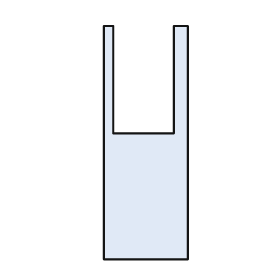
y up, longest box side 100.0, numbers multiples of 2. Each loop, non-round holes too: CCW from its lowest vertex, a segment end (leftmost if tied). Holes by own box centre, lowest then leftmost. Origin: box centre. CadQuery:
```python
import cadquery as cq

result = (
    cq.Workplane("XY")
    .moveTo(-18.0, -50.0)
    .lineTo(18.0, -50.0)
    .lineTo(18.0, 50.0)
    .lineTo(12.0, 50.0)
    .lineTo(12.0, 4.0)
    .lineTo(-14.0, 4.0)
    .lineTo(-14.0, 50.0)
    .lineTo(-18.0, 50.0)
    .close()
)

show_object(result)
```